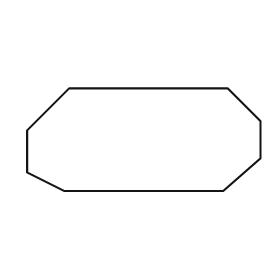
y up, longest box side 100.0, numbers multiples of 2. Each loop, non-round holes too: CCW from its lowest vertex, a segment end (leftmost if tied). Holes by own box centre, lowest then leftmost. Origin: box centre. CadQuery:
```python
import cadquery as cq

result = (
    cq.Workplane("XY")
    .moveTo(-34.0, -22.0)
    .lineTo(34.0, -22.0)
    .lineTo(50.0, -8.0)
    .lineTo(50.0, 8.0)
    .lineTo(36.0, 22.0)
    .lineTo(-32.0, 22.0)
    .lineTo(-50.0, 4.0)
    .lineTo(-50.0, -14.0)
    .close()
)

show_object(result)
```